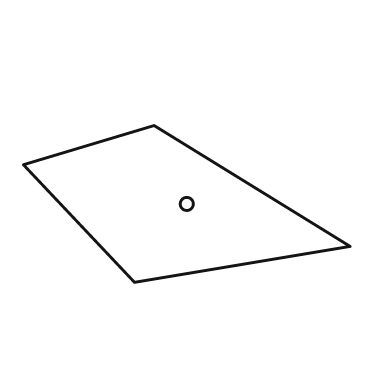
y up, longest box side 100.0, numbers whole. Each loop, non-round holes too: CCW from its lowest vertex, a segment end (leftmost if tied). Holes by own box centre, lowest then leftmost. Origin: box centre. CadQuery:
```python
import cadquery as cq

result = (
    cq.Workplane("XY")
    .moveTo(-16.0, -24.0)
    .lineTo(50.0, -13.0)
    .lineTo(-10.0, 24.0)
    .lineTo(-50.0, 12.0)
    .close()
    .moveTo(0.0, 0.0)
    .circle(2.0)
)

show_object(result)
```